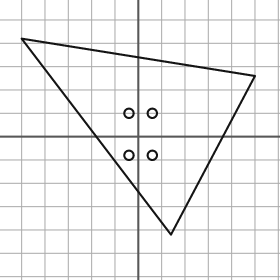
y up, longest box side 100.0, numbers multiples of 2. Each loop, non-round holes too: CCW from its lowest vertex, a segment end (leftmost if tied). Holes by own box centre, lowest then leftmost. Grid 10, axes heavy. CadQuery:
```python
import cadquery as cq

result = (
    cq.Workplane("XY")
    .moveTo(14.0, -42.0)
    .lineTo(50.0, 26.0)
    .lineTo(-50.0, 42.0)
    .close()
    .moveTo(-4.0, -8.0)
    .circle(2.0)
    .moveTo(6.0, -8.0)
    .circle(2.0)
    .moveTo(-4.0, 10.0)
    .circle(2.0)
    .moveTo(6.0, 10.0)
    .circle(2.0)
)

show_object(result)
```